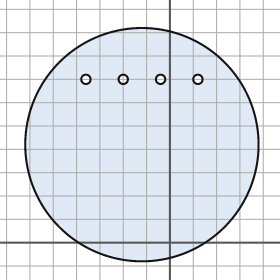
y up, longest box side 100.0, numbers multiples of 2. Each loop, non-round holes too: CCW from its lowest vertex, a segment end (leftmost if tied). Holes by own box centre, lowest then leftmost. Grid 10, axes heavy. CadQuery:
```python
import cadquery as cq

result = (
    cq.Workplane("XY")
    .moveTo(-12.0, 42.0)
    .circle(50.0)
    .moveTo(-36.0, 70.0)
    .circle(2.0)
    .moveTo(-20.0, 70.0)
    .circle(2.0)
    .moveTo(-4.0, 70.0)
    .circle(2.0)
    .moveTo(12.0, 70.0)
    .circle(2.0)
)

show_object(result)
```